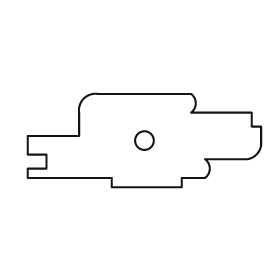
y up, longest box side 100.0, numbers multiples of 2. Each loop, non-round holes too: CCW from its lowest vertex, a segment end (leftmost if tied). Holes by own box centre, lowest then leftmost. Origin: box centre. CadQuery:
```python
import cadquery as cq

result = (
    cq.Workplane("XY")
    .moveTo(-14.0, -20.0)
    .lineTo(16.0, -20.0)
    .lineTo(16.0, -16.0)
    .lineTo(26.0, -16.0)
    .threePointArc((28.0, -12.0), (26.0, -8.0))
    .lineTo(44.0, -8.0)
    .threePointArc((48.0, -6.0), (50.0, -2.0))
    .lineTo(50.0, 6.0)
    .lineTo(46.0, 6.0)
    .lineTo(46.0, 12.0)
    .lineTo(20.0, 12.0)
    .threePointArc((22.0, 16.0), (20.0, 20.0))
    .lineTo(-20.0, 20.0)
    .threePointArc((-26.0, 18.0), (-28.0, 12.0))
    .lineTo(-28.0, 2.0)
    .lineTo(-50.0, 2.0)
    .lineTo(-50.0, -6.0)
    .lineTo(-42.0, -6.0)
    .lineTo(-42.0, -12.0)
    .lineTo(-50.0, -12.0)
    .lineTo(-50.0, -16.0)
    .lineTo(-14.0, -16.0)
    .close()
    .moveTo(0.0, 0.0)
    .circle(4.0)
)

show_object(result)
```